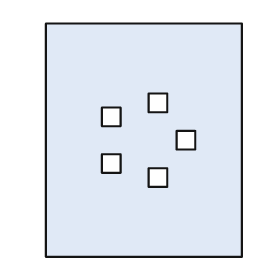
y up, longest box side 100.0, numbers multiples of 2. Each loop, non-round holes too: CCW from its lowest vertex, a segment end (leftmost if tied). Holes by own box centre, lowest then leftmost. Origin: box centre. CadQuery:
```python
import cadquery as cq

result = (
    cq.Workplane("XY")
    .moveTo(-42.0, -50.0)
    .lineTo(42.0, -50.0)
    .lineTo(42.0, 50.0)
    .lineTo(-42.0, 50.0)
    .close()
    .moveTo(2.0, -20.0)
    .lineTo(10.0, -20.0)
    .lineTo(10.0, -12.0)
    .lineTo(2.0, -12.0)
    .close()
    .moveTo(-18.0, -14.0)
    .lineTo(-10.0, -14.0)
    .lineTo(-10.0, -6.0)
    .lineTo(-18.0, -6.0)
    .close()
    .moveTo(14.0, -4.0)
    .lineTo(22.0, -4.0)
    .lineTo(22.0, 4.0)
    .lineTo(14.0, 4.0)
    .close()
    .moveTo(-18.0, 6.0)
    .lineTo(-10.0, 6.0)
    .lineTo(-10.0, 14.0)
    .lineTo(-18.0, 14.0)
    .close()
    .moveTo(2.0, 12.0)
    .lineTo(10.0, 12.0)
    .lineTo(10.0, 20.0)
    .lineTo(2.0, 20.0)
    .close()
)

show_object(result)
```